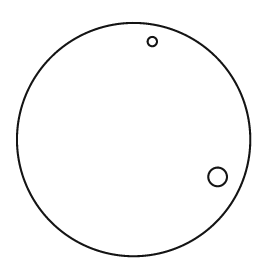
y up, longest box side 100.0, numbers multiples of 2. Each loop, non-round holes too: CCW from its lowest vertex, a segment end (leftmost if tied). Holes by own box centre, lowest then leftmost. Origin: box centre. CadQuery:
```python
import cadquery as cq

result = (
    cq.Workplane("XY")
    .moveTo(0.0, 0.0)
    .circle(50.0)
    .moveTo(36.0, -16.0)
    .circle(4.0)
    .moveTo(8.0, 42.0)
    .circle(2.0)
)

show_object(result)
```